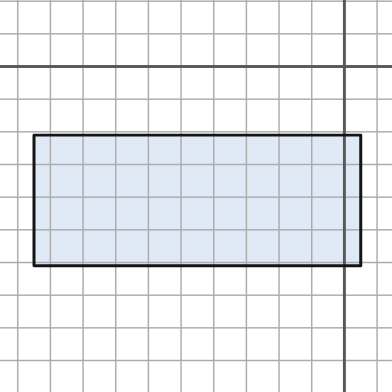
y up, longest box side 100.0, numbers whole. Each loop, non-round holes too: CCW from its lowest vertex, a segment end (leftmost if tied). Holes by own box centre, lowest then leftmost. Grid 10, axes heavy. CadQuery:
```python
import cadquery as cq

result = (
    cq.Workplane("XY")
    .moveTo(-95.0, -61.0)
    .lineTo(5.0, -61.0)
    .lineTo(5.0, -21.0)
    .lineTo(-95.0, -21.0)
    .close()
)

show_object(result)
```